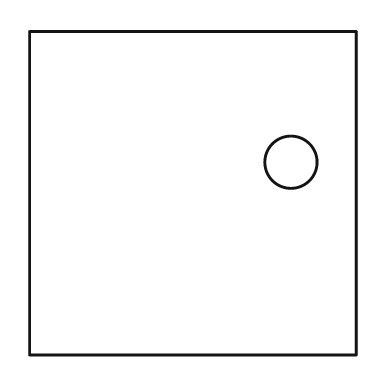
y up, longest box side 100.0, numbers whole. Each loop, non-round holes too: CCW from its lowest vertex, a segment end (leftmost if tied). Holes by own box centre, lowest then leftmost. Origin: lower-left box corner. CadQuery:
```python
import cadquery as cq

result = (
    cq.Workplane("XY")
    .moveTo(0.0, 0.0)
    .lineTo(100.0, 0.0)
    .lineTo(100.0, 99.0)
    .lineTo(0.0, 99.0)
    .close()
    .moveTo(80.0, 59.0)
    .circle(8.0)
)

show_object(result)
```